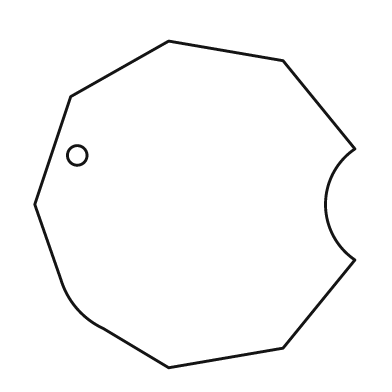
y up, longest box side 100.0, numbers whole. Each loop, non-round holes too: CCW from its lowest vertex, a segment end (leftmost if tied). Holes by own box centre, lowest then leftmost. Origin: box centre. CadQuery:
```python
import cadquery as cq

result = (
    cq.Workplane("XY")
    .moveTo(-8.0, -50.0)
    .lineTo(27.0, -44.0)
    .lineTo(49.0, -17.0)
    .threePointArc((40.0, 0.0), (49.0, 17.0))
    .lineTo(27.0, 44.0)
    .lineTo(-8.0, 50.0)
    .lineTo(-38.0, 33.0)
    .lineTo(-49.0, 0.0)
    .lineTo(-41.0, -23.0)
    .threePointArc((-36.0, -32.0), (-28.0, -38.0))
    .close()
    .moveTo(-36.0, 15.0)
    .circle(3.0)
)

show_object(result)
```